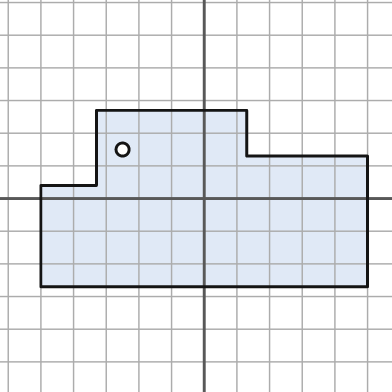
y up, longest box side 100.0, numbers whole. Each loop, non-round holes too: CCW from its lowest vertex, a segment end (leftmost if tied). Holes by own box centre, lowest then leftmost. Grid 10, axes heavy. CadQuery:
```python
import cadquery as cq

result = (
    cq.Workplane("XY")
    .moveTo(-50.0, -27.0)
    .lineTo(50.0, -27.0)
    .lineTo(50.0, 13.0)
    .lineTo(13.0, 13.0)
    .lineTo(13.0, 27.0)
    .lineTo(-33.0, 27.0)
    .lineTo(-33.0, 4.0)
    .lineTo(-50.0, 4.0)
    .close()
    .moveTo(-25.0, 15.0)
    .circle(2.0)
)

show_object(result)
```